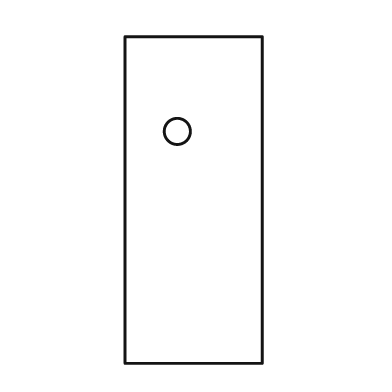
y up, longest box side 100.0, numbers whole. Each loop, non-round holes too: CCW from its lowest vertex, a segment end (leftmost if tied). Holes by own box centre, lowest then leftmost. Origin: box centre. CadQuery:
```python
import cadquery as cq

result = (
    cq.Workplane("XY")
    .moveTo(-21.0, -50.0)
    .lineTo(21.0, -50.0)
    .lineTo(21.0, 50.0)
    .lineTo(-21.0, 50.0)
    .close()
    .moveTo(-5.0, 21.0)
    .circle(4.0)
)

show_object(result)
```